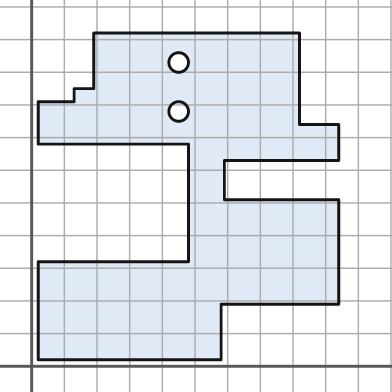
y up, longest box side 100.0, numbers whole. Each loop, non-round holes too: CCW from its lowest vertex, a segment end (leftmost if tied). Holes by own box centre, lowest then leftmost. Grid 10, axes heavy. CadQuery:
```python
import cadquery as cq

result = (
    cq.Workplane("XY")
    .moveTo(2.0, 2.0)
    .lineTo(58.0, 2.0)
    .lineTo(58.0, 19.0)
    .lineTo(94.0, 19.0)
    .lineTo(94.0, 51.0)
    .lineTo(59.0, 51.0)
    .lineTo(59.0, 63.0)
    .lineTo(94.0, 63.0)
    .lineTo(94.0, 74.0)
    .lineTo(82.0, 74.0)
    .lineTo(82.0, 102.0)
    .lineTo(19.0, 102.0)
    .lineTo(19.0, 85.0)
    .lineTo(13.0, 85.0)
    .lineTo(13.0, 81.0)
    .lineTo(2.0, 81.0)
    .lineTo(2.0, 68.0)
    .lineTo(48.0, 68.0)
    .lineTo(48.0, 32.0)
    .lineTo(2.0, 32.0)
    .close()
    .moveTo(45.0, 78.0)
    .circle(3.0)
    .moveTo(45.0, 93.0)
    .circle(3.0)
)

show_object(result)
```